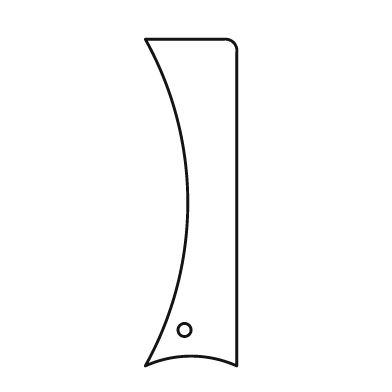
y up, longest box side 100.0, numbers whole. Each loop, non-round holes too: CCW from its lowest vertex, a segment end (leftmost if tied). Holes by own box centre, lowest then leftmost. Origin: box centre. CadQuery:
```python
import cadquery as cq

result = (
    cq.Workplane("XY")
    .moveTo(-14.0, -50.0)
    .threePointArc((0.0, -47.0), (14.0, -50.0))
    .lineTo(14.0, 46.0)
    .threePointArc((13.0, 49.0), (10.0, 50.0))
    .lineTo(-14.0, 50.0)
    .threePointArc((-1.0, 0.0), (-14.0, -50.0))
    .close()
    .moveTo(-2.0, -39.0)
    .circle(2.0)
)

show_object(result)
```